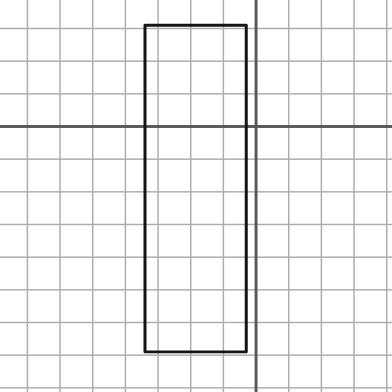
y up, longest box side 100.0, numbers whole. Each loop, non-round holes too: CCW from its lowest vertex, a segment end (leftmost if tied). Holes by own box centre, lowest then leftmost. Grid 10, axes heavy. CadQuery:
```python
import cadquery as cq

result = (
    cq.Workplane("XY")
    .moveTo(-34.0, -69.0)
    .lineTo(-3.0, -69.0)
    .lineTo(-3.0, 31.0)
    .lineTo(-34.0, 31.0)
    .close()
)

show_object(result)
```